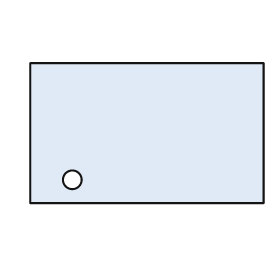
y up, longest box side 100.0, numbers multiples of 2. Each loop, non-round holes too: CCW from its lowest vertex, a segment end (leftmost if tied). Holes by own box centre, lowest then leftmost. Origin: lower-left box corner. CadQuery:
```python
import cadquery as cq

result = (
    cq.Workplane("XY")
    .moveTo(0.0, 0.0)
    .lineTo(100.0, 0.0)
    .lineTo(100.0, 60.0)
    .lineTo(0.0, 60.0)
    .close()
    .moveTo(18.0, 10.0)
    .circle(4.0)
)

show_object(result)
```